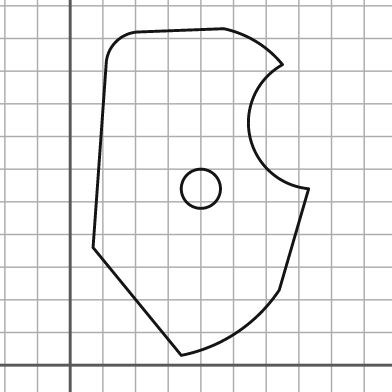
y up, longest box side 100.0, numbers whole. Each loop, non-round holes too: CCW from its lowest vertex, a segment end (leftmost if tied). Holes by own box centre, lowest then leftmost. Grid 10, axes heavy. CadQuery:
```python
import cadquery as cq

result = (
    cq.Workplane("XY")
    .moveTo(34.0, 3.0)
    .threePointArc((51.0, 10.0), (64.0, 23.0))
    .lineTo(73.0, 54.0)
    .threePointArc((55.0, 70.0), (65.0, 92.0))
    .threePointArc((57.0, 99.0), (47.0, 103.0))
    .lineTo(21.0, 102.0)
    .threePointArc((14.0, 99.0), (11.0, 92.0))
    .lineTo(7.0, 36.0)
    .close()
    .moveTo(40.0, 54.0)
    .circle(6.0)
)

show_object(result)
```